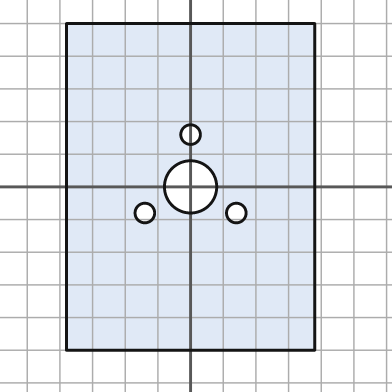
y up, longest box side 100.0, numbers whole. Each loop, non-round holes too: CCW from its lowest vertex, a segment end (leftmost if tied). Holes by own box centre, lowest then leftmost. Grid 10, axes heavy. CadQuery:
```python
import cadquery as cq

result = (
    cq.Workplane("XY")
    .moveTo(-38.0, -50.0)
    .lineTo(38.0, -50.0)
    .lineTo(38.0, 50.0)
    .lineTo(-38.0, 50.0)
    .close()
    .moveTo(-14.0, -8.0)
    .circle(3.0)
    .moveTo(14.0, -8.0)
    .circle(3.0)
    .moveTo(0.0, 0.0)
    .circle(8.0)
    .moveTo(0.0, 16.0)
    .circle(3.0)
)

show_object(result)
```